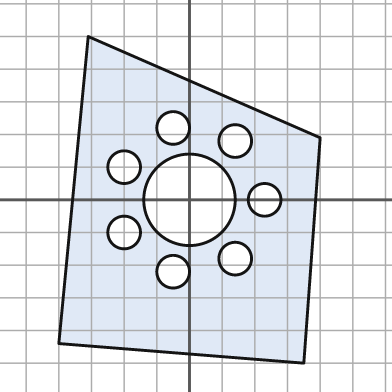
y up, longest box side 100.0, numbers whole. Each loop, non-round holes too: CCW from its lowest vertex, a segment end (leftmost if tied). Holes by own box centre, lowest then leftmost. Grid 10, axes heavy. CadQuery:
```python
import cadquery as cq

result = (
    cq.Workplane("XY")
    .moveTo(35.0, -50.0)
    .lineTo(40.0, 19.0)
    .lineTo(-31.0, 50.0)
    .lineTo(-40.0, -44.0)
    .close()
    .moveTo(-5.0, -22.0)
    .circle(5.0)
    .moveTo(14.0, -18.0)
    .circle(5.0)
    .moveTo(-20.0, -10.0)
    .circle(5.0)
    .moveTo(0.0, 0.0)
    .circle(14.0)
    .moveTo(23.0, 0.0)
    .circle(5.0)
    .moveTo(-20.0, 10.0)
    .circle(5.0)
    .moveTo(14.0, 18.0)
    .circle(5.0)
    .moveTo(-5.0, 22.0)
    .circle(5.0)
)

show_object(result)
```